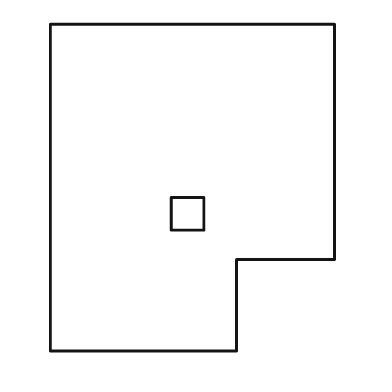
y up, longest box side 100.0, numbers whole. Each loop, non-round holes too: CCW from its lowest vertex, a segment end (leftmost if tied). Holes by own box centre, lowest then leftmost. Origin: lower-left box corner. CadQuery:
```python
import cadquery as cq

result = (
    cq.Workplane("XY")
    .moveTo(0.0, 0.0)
    .lineTo(57.0, 0.0)
    .lineTo(57.0, 28.0)
    .lineTo(87.0, 28.0)
    .lineTo(87.0, 100.0)
    .lineTo(0.0, 100.0)
    .close()
    .moveTo(37.0, 37.0)
    .lineTo(47.0, 37.0)
    .lineTo(47.0, 47.0)
    .lineTo(37.0, 47.0)
    .close()
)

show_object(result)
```